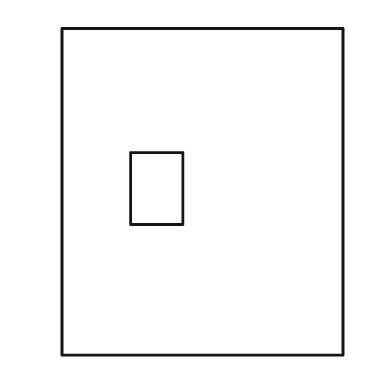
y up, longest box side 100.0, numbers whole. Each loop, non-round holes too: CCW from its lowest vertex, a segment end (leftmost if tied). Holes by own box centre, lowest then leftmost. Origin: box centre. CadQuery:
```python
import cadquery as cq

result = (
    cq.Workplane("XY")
    .moveTo(-43.0, -50.0)
    .lineTo(43.0, -50.0)
    .lineTo(43.0, 50.0)
    .lineTo(-43.0, 50.0)
    .close()
    .moveTo(-22.0, -10.0)
    .lineTo(-6.0, -10.0)
    .lineTo(-6.0, 12.0)
    .lineTo(-22.0, 12.0)
    .close()
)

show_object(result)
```